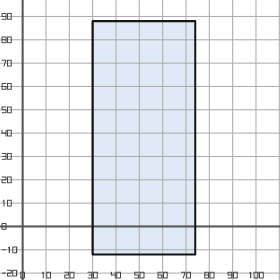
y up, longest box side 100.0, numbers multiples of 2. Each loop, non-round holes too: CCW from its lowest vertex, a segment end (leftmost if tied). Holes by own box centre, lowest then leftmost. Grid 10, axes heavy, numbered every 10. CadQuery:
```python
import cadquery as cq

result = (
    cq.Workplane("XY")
    .moveTo(30.0, -12.0)
    .lineTo(74.0, -12.0)
    .lineTo(74.0, 88.0)
    .lineTo(30.0, 88.0)
    .close()
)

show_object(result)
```